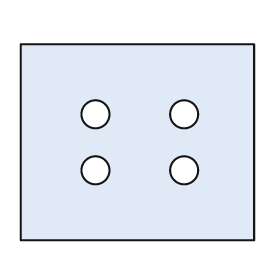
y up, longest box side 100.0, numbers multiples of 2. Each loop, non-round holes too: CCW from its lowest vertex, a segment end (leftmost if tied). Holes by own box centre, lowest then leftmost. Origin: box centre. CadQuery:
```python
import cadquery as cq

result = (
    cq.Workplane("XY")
    .moveTo(-50.0, -42.0)
    .lineTo(50.0, -42.0)
    .lineTo(50.0, 42.0)
    .lineTo(-50.0, 42.0)
    .close()
    .moveTo(-18.0, -12.0)
    .circle(6.0)
    .moveTo(20.0, -12.0)
    .circle(6.0)
    .moveTo(-18.0, 12.0)
    .circle(6.0)
    .moveTo(20.0, 12.0)
    .circle(6.0)
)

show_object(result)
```